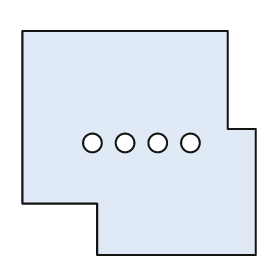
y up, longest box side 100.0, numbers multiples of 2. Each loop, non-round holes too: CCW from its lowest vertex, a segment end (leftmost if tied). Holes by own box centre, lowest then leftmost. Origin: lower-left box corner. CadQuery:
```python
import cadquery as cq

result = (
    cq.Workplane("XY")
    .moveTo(32.0, 0.0)
    .lineTo(100.0, 0.0)
    .lineTo(100.0, 54.0)
    .lineTo(88.0, 54.0)
    .lineTo(88.0, 96.0)
    .lineTo(0.0, 96.0)
    .lineTo(0.0, 22.0)
    .lineTo(32.0, 22.0)
    .close()
    .moveTo(30.0, 48.0)
    .circle(4.0)
    .moveTo(44.0, 48.0)
    .circle(4.0)
    .moveTo(58.0, 48.0)
    .circle(4.0)
    .moveTo(72.0, 48.0)
    .circle(4.0)
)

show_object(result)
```